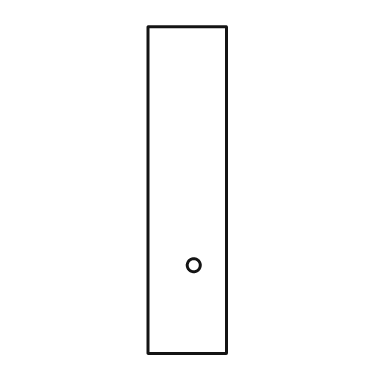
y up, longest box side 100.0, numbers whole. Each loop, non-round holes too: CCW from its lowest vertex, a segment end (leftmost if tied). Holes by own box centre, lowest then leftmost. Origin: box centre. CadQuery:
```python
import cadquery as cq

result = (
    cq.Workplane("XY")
    .moveTo(-12.0, -50.0)
    .lineTo(12.0, -50.0)
    .lineTo(12.0, 50.0)
    .lineTo(-12.0, 50.0)
    .close()
    .moveTo(2.0, -23.0)
    .circle(2.0)
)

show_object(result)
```